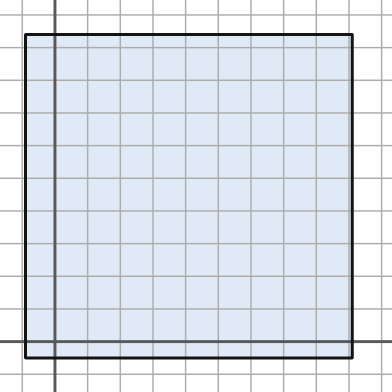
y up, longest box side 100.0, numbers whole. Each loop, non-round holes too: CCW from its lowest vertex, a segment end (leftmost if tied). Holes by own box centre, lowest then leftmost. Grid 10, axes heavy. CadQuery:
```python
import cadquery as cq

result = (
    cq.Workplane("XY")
    .moveTo(-9.0, -5.0)
    .lineTo(91.0, -5.0)
    .lineTo(91.0, 94.0)
    .lineTo(-9.0, 94.0)
    .close()
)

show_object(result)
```